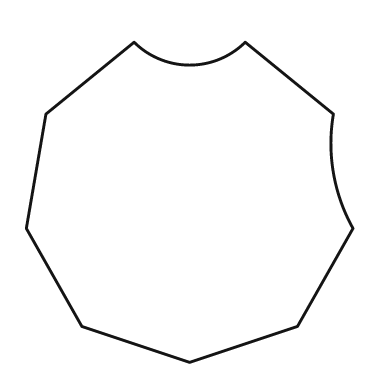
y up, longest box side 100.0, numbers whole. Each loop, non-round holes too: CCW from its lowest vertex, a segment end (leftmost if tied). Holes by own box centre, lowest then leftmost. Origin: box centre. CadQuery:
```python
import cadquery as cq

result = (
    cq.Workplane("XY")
    .moveTo(0.0, -49.0)
    .lineTo(33.0, -38.0)
    .lineTo(50.0, -8.0)
    .threePointArc((44.0, 9.0), (44.0, 27.0))
    .lineTo(17.0, 49.0)
    .threePointArc((0.0, 42.0), (-17.0, 49.0))
    .lineTo(-44.0, 27.0)
    .lineTo(-50.0, -8.0)
    .lineTo(-33.0, -38.0)
    .close()
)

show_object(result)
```